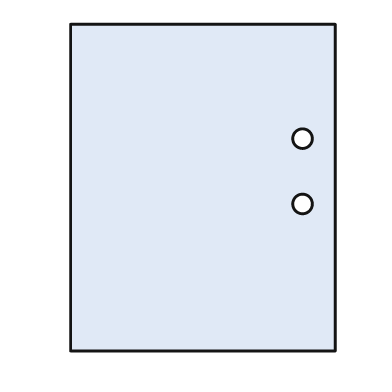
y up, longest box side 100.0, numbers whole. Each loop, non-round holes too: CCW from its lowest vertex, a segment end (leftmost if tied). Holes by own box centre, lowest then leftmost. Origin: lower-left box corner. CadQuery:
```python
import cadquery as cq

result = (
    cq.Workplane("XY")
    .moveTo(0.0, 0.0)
    .lineTo(81.0, 0.0)
    .lineTo(81.0, 100.0)
    .lineTo(0.0, 100.0)
    .close()
    .moveTo(71.0, 45.0)
    .circle(3.0)
    .moveTo(71.0, 65.0)
    .circle(3.0)
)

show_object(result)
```